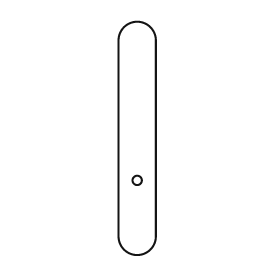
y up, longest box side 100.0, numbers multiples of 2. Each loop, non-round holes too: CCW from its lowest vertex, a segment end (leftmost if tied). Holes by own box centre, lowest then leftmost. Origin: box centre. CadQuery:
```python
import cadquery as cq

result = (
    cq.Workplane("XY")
    .moveTo(-8.0, -42.0)
    .threePointArc((0.0, -50.0), (8.0, -42.0))
    .lineTo(8.0, 42.0)
    .threePointArc((0.0, 50.0), (-8.0, 42.0))
    .close()
    .moveTo(0.0, -18.0)
    .circle(2.0)
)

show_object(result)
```